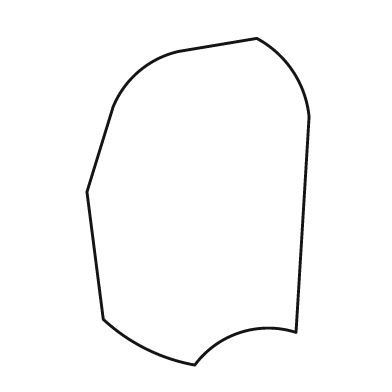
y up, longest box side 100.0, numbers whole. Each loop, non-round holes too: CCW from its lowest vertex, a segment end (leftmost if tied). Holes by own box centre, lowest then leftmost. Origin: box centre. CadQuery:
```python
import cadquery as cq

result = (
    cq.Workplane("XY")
    .moveTo(-1.0, -50.0)
    .threePointArc((13.0, -40.0), (30.0, -40.0))
    .lineTo(34.0, 26.0)
    .threePointArc((29.0, 40.0), (18.0, 50.0))
    .lineTo(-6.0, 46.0)
    .threePointArc((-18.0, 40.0), (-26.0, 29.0))
    .lineTo(-34.0, 3.0)
    .lineTo(-29.0, -36.0)
    .threePointArc((-16.0, -45.0), (-1.0, -50.0))
    .close()
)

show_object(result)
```